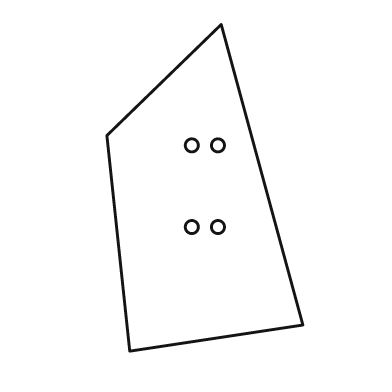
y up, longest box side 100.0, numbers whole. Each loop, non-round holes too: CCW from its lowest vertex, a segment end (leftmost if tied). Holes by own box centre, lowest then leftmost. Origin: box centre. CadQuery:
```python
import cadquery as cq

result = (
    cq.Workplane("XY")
    .moveTo(-23.0, -50.0)
    .lineTo(30.0, -42.0)
    .lineTo(5.0, 50.0)
    .lineTo(-30.0, 16.0)
    .close()
    .moveTo(-4.0, -12.0)
    .circle(2.0)
    .moveTo(4.0, -12.0)
    .circle(2.0)
    .moveTo(-4.0, 13.0)
    .circle(2.0)
    .moveTo(4.0, 13.0)
    .circle(2.0)
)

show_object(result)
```